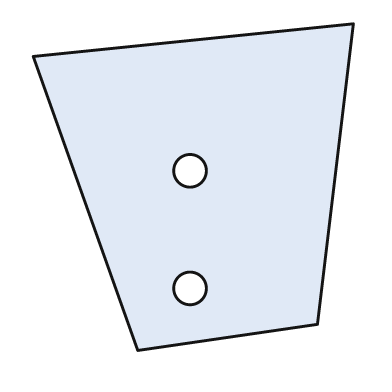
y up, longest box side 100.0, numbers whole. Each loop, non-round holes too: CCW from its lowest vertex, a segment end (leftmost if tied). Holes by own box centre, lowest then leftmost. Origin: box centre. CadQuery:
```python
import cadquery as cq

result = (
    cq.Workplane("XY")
    .moveTo(-17.0, -50.0)
    .lineTo(38.0, -42.0)
    .lineTo(49.0, 50.0)
    .lineTo(-49.0, 40.0)
    .close()
    .moveTo(-1.0, -31.0)
    .circle(5.0)
    .moveTo(-1.0, 5.0)
    .circle(5.0)
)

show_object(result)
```